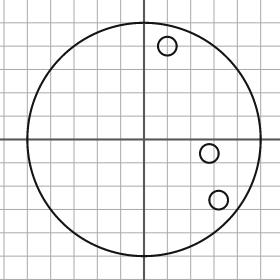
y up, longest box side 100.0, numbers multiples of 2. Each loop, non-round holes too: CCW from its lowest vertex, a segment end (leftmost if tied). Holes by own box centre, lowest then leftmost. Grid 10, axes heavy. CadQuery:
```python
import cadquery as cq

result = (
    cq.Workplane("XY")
    .moveTo(0.0, 0.0)
    .circle(50.0)
    .moveTo(32.0, -26.0)
    .circle(4.0)
    .moveTo(28.0, -6.0)
    .circle(4.0)
    .moveTo(10.0, 40.0)
    .circle(4.0)
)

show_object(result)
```